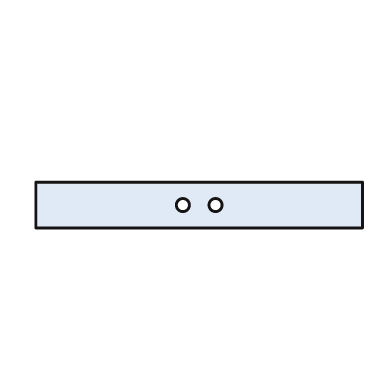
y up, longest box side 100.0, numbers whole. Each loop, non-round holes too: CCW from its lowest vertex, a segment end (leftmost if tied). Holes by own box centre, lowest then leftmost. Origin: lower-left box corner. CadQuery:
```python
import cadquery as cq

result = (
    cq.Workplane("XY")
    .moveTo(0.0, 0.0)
    .lineTo(100.0, 0.0)
    .lineTo(100.0, 14.0)
    .lineTo(0.0, 14.0)
    .close()
    .moveTo(45.0, 7.0)
    .circle(2.0)
    .moveTo(55.0, 7.0)
    .circle(2.0)
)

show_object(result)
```